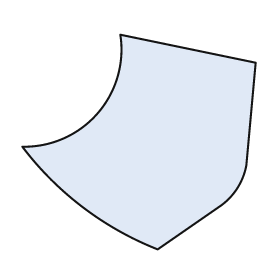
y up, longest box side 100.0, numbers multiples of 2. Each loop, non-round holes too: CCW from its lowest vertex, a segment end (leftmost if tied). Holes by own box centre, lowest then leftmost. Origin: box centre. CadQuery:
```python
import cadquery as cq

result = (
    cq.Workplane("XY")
    .moveTo(8.0, -46.0)
    .lineTo(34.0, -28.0)
    .threePointArc((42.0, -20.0), (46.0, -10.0))
    .lineTo(50.0, 34.0)
    .lineTo(-8.0, 46.0)
    .threePointArc((-18.0, 12.0), (-50.0, -2.0))
    .threePointArc((-24.0, -28.0), (8.0, -46.0))
    .close()
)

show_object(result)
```